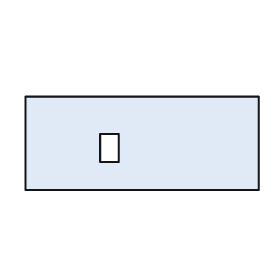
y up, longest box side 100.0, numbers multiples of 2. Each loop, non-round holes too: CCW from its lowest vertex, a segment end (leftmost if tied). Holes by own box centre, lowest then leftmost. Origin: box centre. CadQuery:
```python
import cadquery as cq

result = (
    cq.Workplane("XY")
    .moveTo(-50.0, -20.0)
    .lineTo(50.0, -20.0)
    .lineTo(50.0, 20.0)
    .lineTo(-50.0, 20.0)
    .close()
    .moveTo(-18.0, -8.0)
    .lineTo(-10.0, -8.0)
    .lineTo(-10.0, 4.0)
    .lineTo(-18.0, 4.0)
    .close()
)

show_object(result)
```